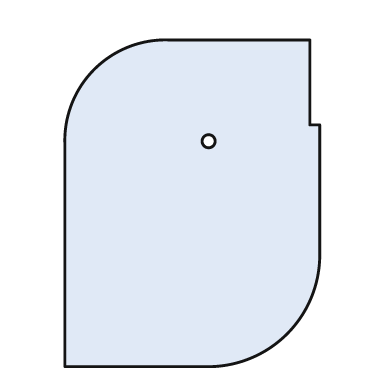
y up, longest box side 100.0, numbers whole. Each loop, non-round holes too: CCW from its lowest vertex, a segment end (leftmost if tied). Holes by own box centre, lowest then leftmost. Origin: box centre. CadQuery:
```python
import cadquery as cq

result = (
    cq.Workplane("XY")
    .moveTo(-39.0, -50.0)
    .lineTo(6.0, -50.0)
    .threePointArc((29.0, -40.0), (39.0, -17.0))
    .lineTo(39.0, 24.0)
    .lineTo(36.0, 24.0)
    .lineTo(36.0, 50.0)
    .lineTo(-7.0, 50.0)
    .threePointArc((-30.0, 41.0), (-39.0, 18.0))
    .close()
    .moveTo(5.0, 19.0)
    .circle(2.0)
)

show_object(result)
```